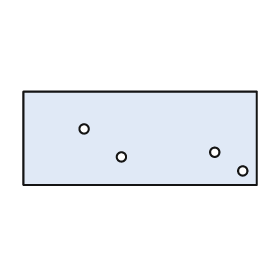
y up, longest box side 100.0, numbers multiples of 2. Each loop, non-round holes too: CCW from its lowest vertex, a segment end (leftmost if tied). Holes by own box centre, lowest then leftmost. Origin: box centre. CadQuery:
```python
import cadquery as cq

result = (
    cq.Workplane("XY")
    .moveTo(-50.0, -20.0)
    .lineTo(50.0, -20.0)
    .lineTo(50.0, 20.0)
    .lineTo(-50.0, 20.0)
    .close()
    .moveTo(44.0, -14.0)
    .circle(2.0)
    .moveTo(-8.0, -8.0)
    .circle(2.0)
    .moveTo(32.0, -6.0)
    .circle(2.0)
    .moveTo(-24.0, 4.0)
    .circle(2.0)
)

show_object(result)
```